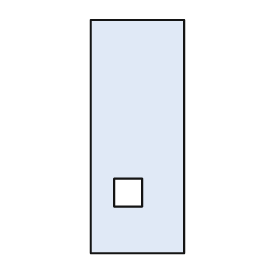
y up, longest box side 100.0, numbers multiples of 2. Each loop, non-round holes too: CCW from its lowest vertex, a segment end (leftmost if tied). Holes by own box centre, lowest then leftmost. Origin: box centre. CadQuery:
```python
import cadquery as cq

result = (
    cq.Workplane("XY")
    .moveTo(-20.0, -50.0)
    .lineTo(20.0, -50.0)
    .lineTo(20.0, 50.0)
    .lineTo(-20.0, 50.0)
    .close()
    .moveTo(-10.0, -30.0)
    .lineTo(2.0, -30.0)
    .lineTo(2.0, -18.0)
    .lineTo(-10.0, -18.0)
    .close()
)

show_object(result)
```